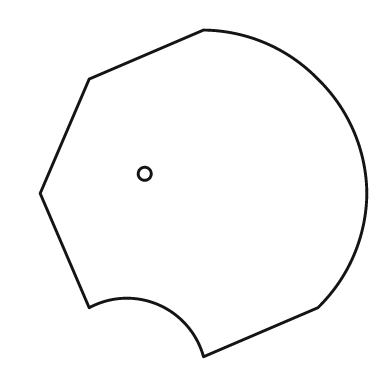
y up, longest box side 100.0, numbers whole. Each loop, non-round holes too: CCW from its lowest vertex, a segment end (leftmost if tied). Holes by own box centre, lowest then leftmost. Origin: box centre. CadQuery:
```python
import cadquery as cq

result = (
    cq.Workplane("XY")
    .moveTo(0.0, -50.0)
    .lineTo(35.0, -35.0)
    .threePointArc((46.0, -19.0), (50.0, 0.0))
    .threePointArc((46.0, 19.0), (35.0, 35.0))
    .threePointArc((19.0, 46.0), (0.0, 50.0))
    .lineTo(-35.0, 35.0)
    .lineTo(-50.0, 0.0)
    .lineTo(-35.0, -35.0)
    .threePointArc((-14.0, -34.0), (0.0, -50.0))
    .close()
    .moveTo(-18.0, 6.0)
    .circle(2.0)
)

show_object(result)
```